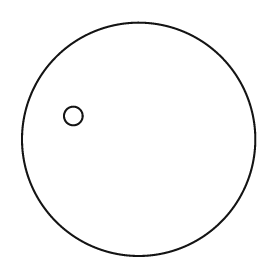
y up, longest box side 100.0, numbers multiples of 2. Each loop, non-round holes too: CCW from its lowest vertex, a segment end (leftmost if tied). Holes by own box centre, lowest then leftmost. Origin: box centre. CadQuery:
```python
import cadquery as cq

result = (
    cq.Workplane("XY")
    .moveTo(0.0, 0.0)
    .circle(50.0)
    .moveTo(-28.0, 10.0)
    .circle(4.0)
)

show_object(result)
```